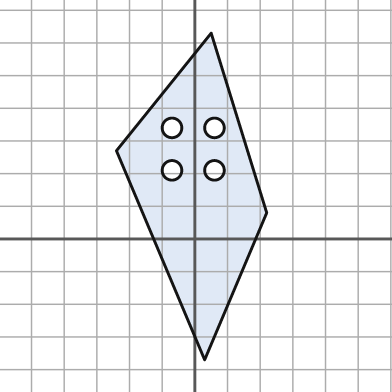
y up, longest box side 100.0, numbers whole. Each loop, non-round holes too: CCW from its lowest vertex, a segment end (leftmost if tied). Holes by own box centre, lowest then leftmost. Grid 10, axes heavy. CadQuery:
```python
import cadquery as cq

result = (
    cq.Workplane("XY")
    .moveTo(3.0, -37.0)
    .lineTo(22.0, 8.0)
    .lineTo(5.0, 63.0)
    .lineTo(-24.0, 27.0)
    .close()
    .moveTo(-7.0, 21.0)
    .circle(3.0)
    .moveTo(6.0, 21.0)
    .circle(3.0)
    .moveTo(-7.0, 34.0)
    .circle(3.0)
    .moveTo(6.0, 34.0)
    .circle(3.0)
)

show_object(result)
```